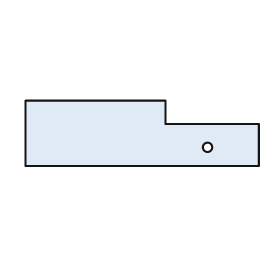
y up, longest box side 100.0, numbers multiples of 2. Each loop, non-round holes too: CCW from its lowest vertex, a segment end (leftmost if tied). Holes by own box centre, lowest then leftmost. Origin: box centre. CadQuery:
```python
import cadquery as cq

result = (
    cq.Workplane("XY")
    .moveTo(-50.0, -14.0)
    .lineTo(50.0, -14.0)
    .lineTo(50.0, 4.0)
    .lineTo(10.0, 4.0)
    .lineTo(10.0, 14.0)
    .lineTo(-50.0, 14.0)
    .close()
    .moveTo(28.0, -6.0)
    .circle(2.0)
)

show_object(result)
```